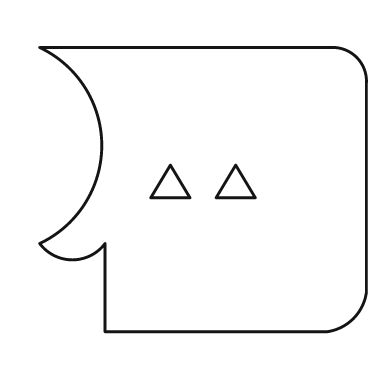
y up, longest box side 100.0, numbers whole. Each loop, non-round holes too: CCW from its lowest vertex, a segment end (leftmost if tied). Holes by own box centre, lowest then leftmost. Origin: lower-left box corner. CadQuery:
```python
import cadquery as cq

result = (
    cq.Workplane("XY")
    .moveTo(20.0, 0.0)
    .lineTo(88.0, 0.0)
    .threePointArc((96.0, 4.0), (100.0, 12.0))
    .lineTo(100.0, 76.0)
    .threePointArc((97.0, 84.0), (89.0, 87.0))
    .lineTo(0.0, 87.0)
    .threePointArc((19.0, 57.0), (0.0, 27.0))
    .threePointArc((10.0, 22.0), (20.0, 27.0))
    .close()
    .moveTo(34.0, 41.0)
    .lineTo(46.0, 41.0)
    .lineTo(40.0, 51.0)
    .close()
    .moveTo(54.0, 41.0)
    .lineTo(66.0, 41.0)
    .lineTo(60.0, 51.0)
    .close()
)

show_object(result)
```